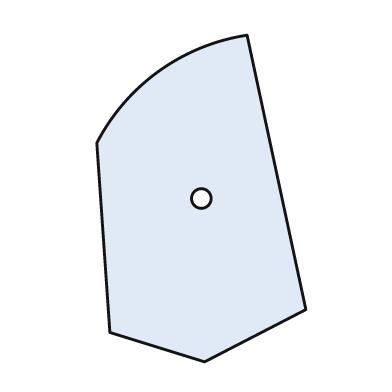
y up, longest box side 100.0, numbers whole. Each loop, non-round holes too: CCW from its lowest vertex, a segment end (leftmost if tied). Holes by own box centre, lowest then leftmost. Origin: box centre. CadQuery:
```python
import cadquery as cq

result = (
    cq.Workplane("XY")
    .moveTo(1.0, -50.0)
    .lineTo(32.0, -34.0)
    .lineTo(14.0, 50.0)
    .threePointArc((-13.0, 39.0), (-32.0, 17.0))
    .lineTo(-28.0, -41.0)
    .close()
    .moveTo(0.0, 0.0)
    .circle(3.0)
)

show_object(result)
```